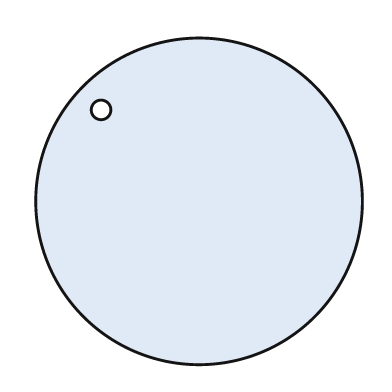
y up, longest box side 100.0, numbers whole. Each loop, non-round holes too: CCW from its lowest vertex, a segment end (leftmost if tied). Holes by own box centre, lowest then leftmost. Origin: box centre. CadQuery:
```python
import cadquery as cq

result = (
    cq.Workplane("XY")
    .moveTo(0.0, 0.0)
    .circle(50.0)
    .moveTo(-30.0, 28.0)
    .circle(3.0)
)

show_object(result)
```